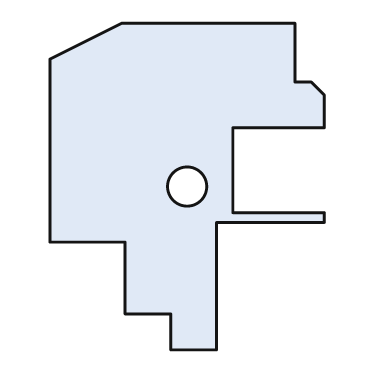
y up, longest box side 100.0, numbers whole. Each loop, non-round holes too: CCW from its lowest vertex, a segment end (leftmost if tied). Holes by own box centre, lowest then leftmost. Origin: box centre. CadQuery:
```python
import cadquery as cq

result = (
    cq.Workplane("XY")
    .moveTo(-5.0, -50.0)
    .lineTo(9.0, -50.0)
    .lineTo(9.0, -11.0)
    .lineTo(42.0, -11.0)
    .lineTo(42.0, -8.0)
    .lineTo(14.0, -8.0)
    .lineTo(14.0, 18.0)
    .lineTo(42.0, 18.0)
    .lineTo(42.0, 28.0)
    .lineTo(38.0, 32.0)
    .lineTo(33.0, 32.0)
    .lineTo(33.0, 50.0)
    .lineTo(-20.0, 50.0)
    .lineTo(-42.0, 39.0)
    .lineTo(-42.0, -17.0)
    .lineTo(-19.0, -17.0)
    .lineTo(-19.0, -39.0)
    .lineTo(-5.0, -39.0)
    .close()
    .moveTo(0.0, 0.0)
    .circle(6.0)
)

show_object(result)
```